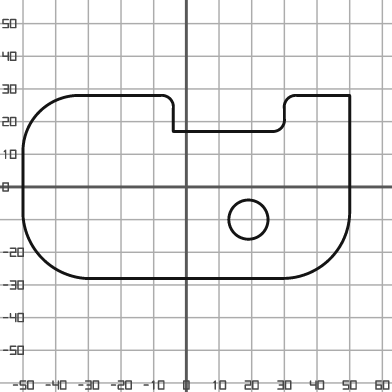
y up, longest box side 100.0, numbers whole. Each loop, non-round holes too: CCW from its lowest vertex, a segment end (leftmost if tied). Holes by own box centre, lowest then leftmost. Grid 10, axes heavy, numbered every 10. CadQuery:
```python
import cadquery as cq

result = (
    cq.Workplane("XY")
    .moveTo(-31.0, -28.0)
    .lineTo(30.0, -28.0)
    .threePointArc((44.0, -22.0), (50.0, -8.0))
    .lineTo(50.0, 28.0)
    .lineTo(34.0, 28.0)
    .threePointArc((31.0, 27.0), (30.0, 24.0))
    .lineTo(30.0, 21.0)
    .threePointArc((29.0, 18.0), (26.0, 17.0))
    .lineTo(-4.0, 17.0)
    .lineTo(-4.0, 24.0)
    .threePointArc((-5.0, 27.0), (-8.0, 28.0))
    .lineTo(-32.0, 28.0)
    .threePointArc((-45.0, 23.0), (-50.0, 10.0))
    .lineTo(-50.0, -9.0)
    .threePointArc((-44.0, -22.0), (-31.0, -28.0))
    .close()
    .moveTo(19.0, -10.0)
    .circle(6.0)
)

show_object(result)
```